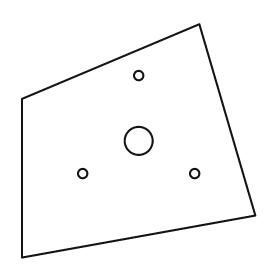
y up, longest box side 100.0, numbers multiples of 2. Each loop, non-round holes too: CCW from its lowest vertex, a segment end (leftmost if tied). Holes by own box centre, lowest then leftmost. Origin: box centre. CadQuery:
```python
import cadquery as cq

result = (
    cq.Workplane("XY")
    .moveTo(-50.0, -50.0)
    .lineTo(50.0, -32.0)
    .lineTo(26.0, 50.0)
    .lineTo(-50.0, 18.0)
    .close()
    .moveTo(-24.0, -14.0)
    .circle(2.0)
    .moveTo(24.0, -14.0)
    .circle(2.0)
    .moveTo(0.0, 0.0)
    .circle(6.0)
    .moveTo(0.0, 28.0)
    .circle(2.0)
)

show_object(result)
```